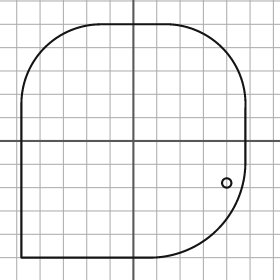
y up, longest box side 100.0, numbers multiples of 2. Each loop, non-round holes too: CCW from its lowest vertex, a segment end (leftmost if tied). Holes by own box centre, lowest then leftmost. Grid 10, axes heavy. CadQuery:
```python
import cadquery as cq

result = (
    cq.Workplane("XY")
    .moveTo(-48.0, -50.0)
    .lineTo(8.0, -50.0)
    .threePointArc((36.0, -38.0), (48.0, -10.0))
    .lineTo(48.0, 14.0)
    .threePointArc((38.0, 40.0), (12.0, 50.0))
    .lineTo(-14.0, 50.0)
    .threePointArc((-38.0, 40.0), (-48.0, 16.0))
    .close()
    .moveTo(40.0, -18.0)
    .circle(2.0)
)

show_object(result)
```